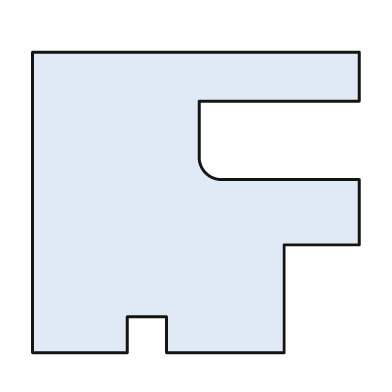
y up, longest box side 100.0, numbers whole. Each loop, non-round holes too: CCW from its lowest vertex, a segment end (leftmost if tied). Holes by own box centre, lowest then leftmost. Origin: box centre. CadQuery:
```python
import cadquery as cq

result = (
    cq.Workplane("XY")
    .moveTo(-50.0, -46.0)
    .lineTo(-21.0, -46.0)
    .lineTo(-21.0, -35.0)
    .lineTo(-9.0, -35.0)
    .lineTo(-9.0, -46.0)
    .lineTo(27.0, -46.0)
    .lineTo(27.0, -13.0)
    .lineTo(50.0, -13.0)
    .lineTo(50.0, 7.0)
    .lineTo(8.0, 7.0)
    .threePointArc((3.0, 9.0), (1.0, 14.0))
    .lineTo(1.0, 31.0)
    .lineTo(50.0, 31.0)
    .lineTo(50.0, 46.0)
    .lineTo(-50.0, 46.0)
    .close()
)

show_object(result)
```